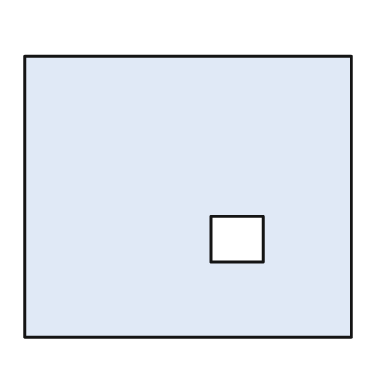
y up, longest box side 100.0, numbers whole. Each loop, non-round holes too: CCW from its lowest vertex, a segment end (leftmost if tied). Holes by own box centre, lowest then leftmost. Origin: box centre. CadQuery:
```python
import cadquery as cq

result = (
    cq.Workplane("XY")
    .moveTo(-50.0, -43.0)
    .lineTo(50.0, -43.0)
    .lineTo(50.0, 43.0)
    .lineTo(-50.0, 43.0)
    .close()
    .moveTo(7.0, -20.0)
    .lineTo(23.0, -20.0)
    .lineTo(23.0, -6.0)
    .lineTo(7.0, -6.0)
    .close()
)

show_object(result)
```